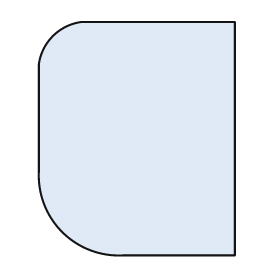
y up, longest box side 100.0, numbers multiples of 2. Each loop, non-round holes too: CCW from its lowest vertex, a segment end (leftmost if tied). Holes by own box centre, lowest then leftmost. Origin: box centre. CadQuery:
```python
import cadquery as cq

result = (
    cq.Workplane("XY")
    .moveTo(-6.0, -50.0)
    .lineTo(42.0, -50.0)
    .lineTo(42.0, 50.0)
    .lineTo(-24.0, 50.0)
    .threePointArc((-36.0, 44.0), (-42.0, 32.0))
    .lineTo(-42.0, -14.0)
    .threePointArc((-32.0, -40.0), (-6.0, -50.0))
    .close()
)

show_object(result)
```